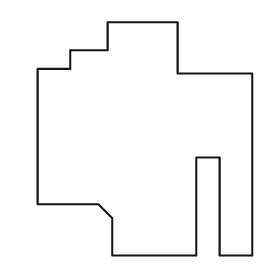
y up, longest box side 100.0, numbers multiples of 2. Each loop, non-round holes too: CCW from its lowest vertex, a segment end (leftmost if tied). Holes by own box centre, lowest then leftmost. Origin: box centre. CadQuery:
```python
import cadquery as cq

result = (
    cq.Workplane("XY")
    .moveTo(-14.0, -50.0)
    .lineTo(22.0, -50.0)
    .lineTo(22.0, -8.0)
    .lineTo(32.0, -8.0)
    .lineTo(32.0, -50.0)
    .lineTo(46.0, -50.0)
    .lineTo(46.0, 28.0)
    .lineTo(14.0, 28.0)
    .lineTo(14.0, 50.0)
    .lineTo(-16.0, 50.0)
    .lineTo(-16.0, 38.0)
    .lineTo(-32.0, 38.0)
    .lineTo(-32.0, 30.0)
    .lineTo(-46.0, 30.0)
    .lineTo(-46.0, -28.0)
    .lineTo(-20.0, -28.0)
    .lineTo(-14.0, -34.0)
    .close()
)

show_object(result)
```